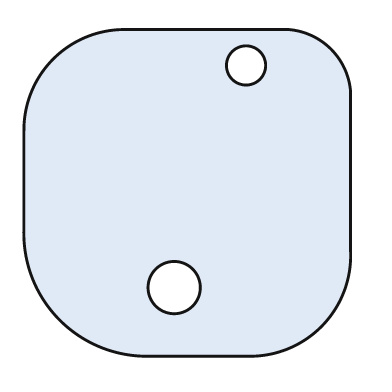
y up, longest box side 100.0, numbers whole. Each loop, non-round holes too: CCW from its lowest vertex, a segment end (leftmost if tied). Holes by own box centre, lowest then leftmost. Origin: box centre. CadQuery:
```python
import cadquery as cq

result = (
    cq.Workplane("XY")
    .moveTo(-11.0, -50.0)
    .lineTo(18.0, -50.0)
    .threePointArc((41.0, -41.0), (50.0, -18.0))
    .lineTo(50.0, 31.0)
    .threePointArc((44.0, 44.0), (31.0, 50.0))
    .lineTo(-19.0, 50.0)
    .threePointArc((-41.0, 41.0), (-50.0, 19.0))
    .lineTo(-50.0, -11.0)
    .threePointArc((-39.0, -39.0), (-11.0, -50.0))
    .close()
    .moveTo(-4.0, -29.0)
    .circle(8.0)
    .moveTo(18.0, 39.0)
    .circle(6.0)
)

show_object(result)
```